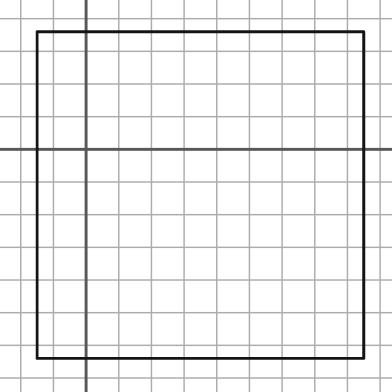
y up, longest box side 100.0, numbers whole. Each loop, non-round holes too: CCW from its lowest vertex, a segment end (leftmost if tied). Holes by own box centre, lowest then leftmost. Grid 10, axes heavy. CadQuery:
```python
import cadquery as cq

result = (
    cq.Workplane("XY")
    .moveTo(-15.0, -64.0)
    .lineTo(85.0, -64.0)
    .lineTo(85.0, 36.0)
    .lineTo(-15.0, 36.0)
    .close()
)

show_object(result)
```